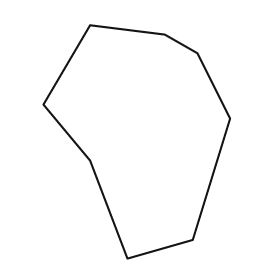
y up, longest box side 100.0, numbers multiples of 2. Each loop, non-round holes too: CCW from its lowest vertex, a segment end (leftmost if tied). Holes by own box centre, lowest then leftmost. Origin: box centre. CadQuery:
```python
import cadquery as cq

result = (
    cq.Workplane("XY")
    .moveTo(-4.0, -50.0)
    .lineTo(24.0, -42.0)
    .lineTo(40.0, 10.0)
    .lineTo(26.0, 38.0)
    .lineTo(12.0, 46.0)
    .lineTo(-20.0, 50.0)
    .lineTo(-40.0, 16.0)
    .lineTo(-20.0, -8.0)
    .close()
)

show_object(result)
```